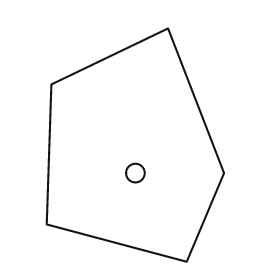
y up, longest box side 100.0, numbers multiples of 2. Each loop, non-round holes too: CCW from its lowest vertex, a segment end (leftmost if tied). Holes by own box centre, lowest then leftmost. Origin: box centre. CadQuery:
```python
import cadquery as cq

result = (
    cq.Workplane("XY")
    .moveTo(22.0, -50.0)
    .lineTo(38.0, -12.0)
    .lineTo(14.0, 50.0)
    .lineTo(-36.0, 26.0)
    .lineTo(-38.0, -34.0)
    .close()
    .moveTo(0.0, -12.0)
    .circle(4.0)
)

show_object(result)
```